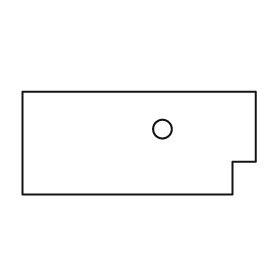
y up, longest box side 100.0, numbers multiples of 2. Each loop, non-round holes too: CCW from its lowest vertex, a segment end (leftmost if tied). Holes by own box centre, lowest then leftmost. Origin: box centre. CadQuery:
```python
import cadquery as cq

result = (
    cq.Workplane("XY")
    .moveTo(-50.0, -22.0)
    .lineTo(40.0, -22.0)
    .lineTo(40.0, -8.0)
    .lineTo(50.0, -8.0)
    .lineTo(50.0, 22.0)
    .lineTo(-50.0, 22.0)
    .close()
    .moveTo(10.0, 6.0)
    .circle(4.0)
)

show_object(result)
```